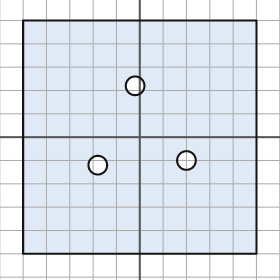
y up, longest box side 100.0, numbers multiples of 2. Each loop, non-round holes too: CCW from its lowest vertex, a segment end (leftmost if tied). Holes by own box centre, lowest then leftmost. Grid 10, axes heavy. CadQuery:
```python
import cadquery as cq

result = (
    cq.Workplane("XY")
    .moveTo(-50.0, -50.0)
    .lineTo(50.0, -50.0)
    .lineTo(50.0, 50.0)
    .lineTo(-50.0, 50.0)
    .close()
    .moveTo(-18.0, -12.0)
    .circle(4.0)
    .moveTo(20.0, -10.0)
    .circle(4.0)
    .moveTo(-2.0, 22.0)
    .circle(4.0)
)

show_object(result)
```